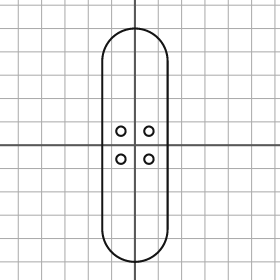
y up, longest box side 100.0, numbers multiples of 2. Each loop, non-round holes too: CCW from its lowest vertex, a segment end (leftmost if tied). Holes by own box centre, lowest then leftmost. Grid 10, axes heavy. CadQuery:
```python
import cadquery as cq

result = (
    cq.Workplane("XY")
    .moveTo(-14.0, -36.0)
    .threePointArc((0.0, -50.0), (14.0, -36.0))
    .lineTo(14.0, 36.0)
    .threePointArc((0.0, 50.0), (-14.0, 36.0))
    .close()
    .moveTo(-6.0, -6.0)
    .circle(2.0)
    .moveTo(6.0, -6.0)
    .circle(2.0)
    .moveTo(-6.0, 6.0)
    .circle(2.0)
    .moveTo(6.0, 6.0)
    .circle(2.0)
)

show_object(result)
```